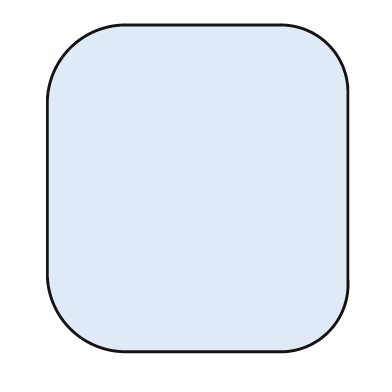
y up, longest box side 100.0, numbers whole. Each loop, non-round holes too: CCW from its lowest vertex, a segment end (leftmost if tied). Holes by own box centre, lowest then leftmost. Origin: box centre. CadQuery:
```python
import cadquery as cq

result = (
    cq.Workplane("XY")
    .moveTo(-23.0, -50.0)
    .lineTo(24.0, -50.0)
    .threePointArc((40.0, -44.0), (46.0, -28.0))
    .lineTo(46.0, 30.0)
    .threePointArc((40.0, 44.0), (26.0, 50.0))
    .lineTo(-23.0, 50.0)
    .threePointArc((-39.0, 43.0), (-46.0, 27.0))
    .lineTo(-46.0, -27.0)
    .threePointArc((-39.0, -43.0), (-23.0, -50.0))
    .close()
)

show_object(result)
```